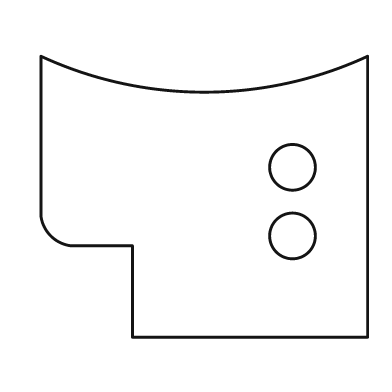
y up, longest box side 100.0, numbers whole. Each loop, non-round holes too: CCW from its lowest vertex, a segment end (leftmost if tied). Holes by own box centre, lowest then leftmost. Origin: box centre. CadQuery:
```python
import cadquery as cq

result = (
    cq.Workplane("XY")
    .moveTo(-22.0, -43.0)
    .lineTo(50.0, -43.0)
    .lineTo(50.0, 43.0)
    .threePointArc((0.0, 32.0), (-50.0, 43.0))
    .lineTo(-50.0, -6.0)
    .threePointArc((-47.0, -12.0), (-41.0, -15.0))
    .lineTo(-22.0, -15.0)
    .close()
    .moveTo(27.0, -12.0)
    .circle(7.0)
    .moveTo(27.0, 9.0)
    .circle(7.0)
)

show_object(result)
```